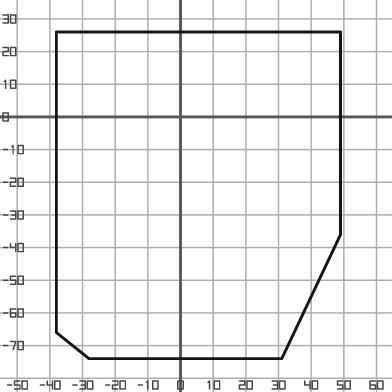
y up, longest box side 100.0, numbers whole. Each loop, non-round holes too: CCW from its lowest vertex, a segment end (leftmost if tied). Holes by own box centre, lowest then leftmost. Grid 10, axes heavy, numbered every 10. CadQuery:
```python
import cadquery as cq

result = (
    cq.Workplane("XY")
    .moveTo(-28.0, -74.0)
    .lineTo(31.0, -74.0)
    .lineTo(49.0, -36.0)
    .lineTo(49.0, 26.0)
    .lineTo(-38.0, 26.0)
    .lineTo(-38.0, -66.0)
    .close()
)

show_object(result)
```